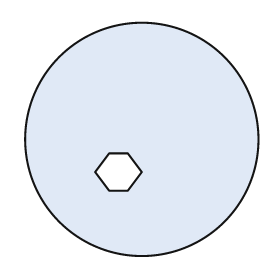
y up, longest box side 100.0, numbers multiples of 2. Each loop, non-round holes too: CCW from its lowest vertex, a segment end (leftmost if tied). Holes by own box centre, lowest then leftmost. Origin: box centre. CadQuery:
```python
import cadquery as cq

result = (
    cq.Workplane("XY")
    .moveTo(0.0, 0.0)
    .circle(50.0)
    .moveTo(-14.0, -22.0)
    .lineTo(-6.0, -22.0)
    .lineTo(0.0, -14.0)
    .lineTo(-6.0, -6.0)
    .lineTo(-14.0, -6.0)
    .lineTo(-20.0, -14.0)
    .close()
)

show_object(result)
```